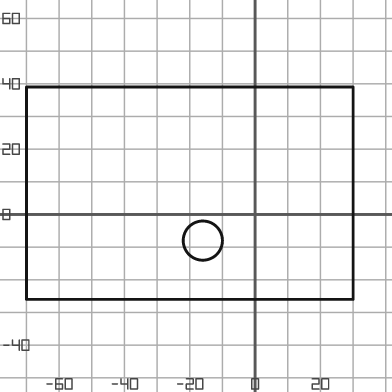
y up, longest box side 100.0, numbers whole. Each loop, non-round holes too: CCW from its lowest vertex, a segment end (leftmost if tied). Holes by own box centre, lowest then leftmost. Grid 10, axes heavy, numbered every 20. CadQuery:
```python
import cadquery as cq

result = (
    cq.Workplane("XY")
    .moveTo(-70.0, -26.0)
    .lineTo(30.0, -26.0)
    .lineTo(30.0, 39.0)
    .lineTo(-70.0, 39.0)
    .close()
    .moveTo(-16.0, -8.0)
    .circle(6.0)
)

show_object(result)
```